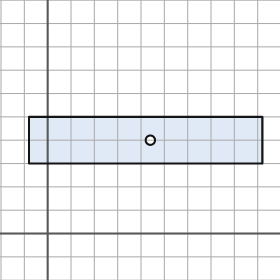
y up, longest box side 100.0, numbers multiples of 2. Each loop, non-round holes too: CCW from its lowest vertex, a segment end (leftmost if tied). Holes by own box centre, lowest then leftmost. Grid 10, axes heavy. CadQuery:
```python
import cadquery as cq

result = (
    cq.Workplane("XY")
    .moveTo(-8.0, 30.0)
    .lineTo(92.0, 30.0)
    .lineTo(92.0, 50.0)
    .lineTo(-8.0, 50.0)
    .close()
    .moveTo(44.0, 40.0)
    .circle(2.0)
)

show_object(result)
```